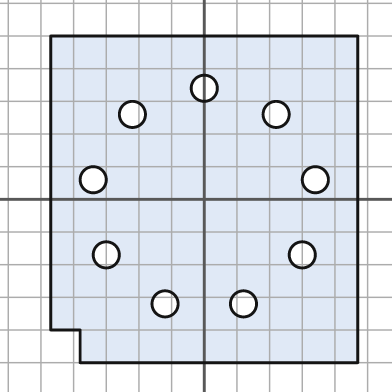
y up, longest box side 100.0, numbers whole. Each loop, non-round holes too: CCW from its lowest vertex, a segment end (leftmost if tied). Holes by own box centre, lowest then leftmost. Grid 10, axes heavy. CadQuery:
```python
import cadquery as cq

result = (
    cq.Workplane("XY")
    .moveTo(-38.0, -50.0)
    .lineTo(47.0, -50.0)
    .lineTo(47.0, 50.0)
    .lineTo(-47.0, 50.0)
    .lineTo(-47.0, -40.0)
    .lineTo(-38.0, -40.0)
    .close()
    .moveTo(-12.0, -32.0)
    .circle(4.0)
    .moveTo(12.0, -32.0)
    .circle(4.0)
    .moveTo(-30.0, -17.0)
    .circle(4.0)
    .moveTo(30.0, -17.0)
    .circle(4.0)
    .moveTo(-34.0, 6.0)
    .circle(4.0)
    .moveTo(34.0, 6.0)
    .circle(4.0)
    .moveTo(-22.0, 26.0)
    .circle(4.0)
    .moveTo(22.0, 26.0)
    .circle(4.0)
    .moveTo(0.0, 34.0)
    .circle(4.0)
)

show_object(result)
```